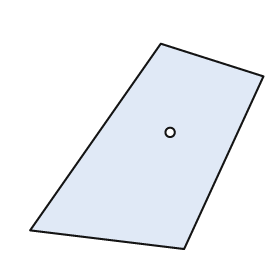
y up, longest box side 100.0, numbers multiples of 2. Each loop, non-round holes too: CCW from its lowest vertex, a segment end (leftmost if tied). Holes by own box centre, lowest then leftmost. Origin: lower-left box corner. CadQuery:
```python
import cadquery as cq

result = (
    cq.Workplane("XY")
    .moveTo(66.0, 0.0)
    .lineTo(100.0, 74.0)
    .lineTo(56.0, 88.0)
    .lineTo(0.0, 8.0)
    .close()
    .moveTo(60.0, 50.0)
    .circle(2.0)
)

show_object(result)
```